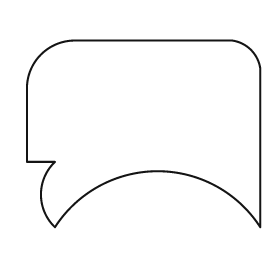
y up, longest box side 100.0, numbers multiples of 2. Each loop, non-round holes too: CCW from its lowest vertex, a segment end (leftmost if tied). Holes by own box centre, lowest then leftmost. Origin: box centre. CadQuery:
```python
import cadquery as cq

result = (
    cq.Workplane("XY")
    .moveTo(-38.0, -40.0)
    .threePointArc((6.0, -16.0), (50.0, -40.0))
    .lineTo(50.0, 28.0)
    .threePointArc((46.0, 36.0), (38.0, 40.0))
    .lineTo(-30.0, 40.0)
    .threePointArc((-44.0, 34.0), (-50.0, 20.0))
    .lineTo(-50.0, -12.0)
    .lineTo(-38.0, -12.0)
    .threePointArc((-44.0, -26.0), (-38.0, -40.0))
    .close()
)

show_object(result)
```